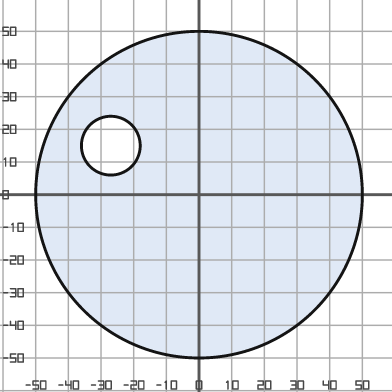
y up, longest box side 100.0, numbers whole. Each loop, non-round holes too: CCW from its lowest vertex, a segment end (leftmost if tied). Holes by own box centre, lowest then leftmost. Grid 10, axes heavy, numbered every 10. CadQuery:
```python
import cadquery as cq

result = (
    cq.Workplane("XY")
    .moveTo(0.0, 0.0)
    .circle(50.0)
    .moveTo(-27.0, 15.0)
    .circle(9.0)
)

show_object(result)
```